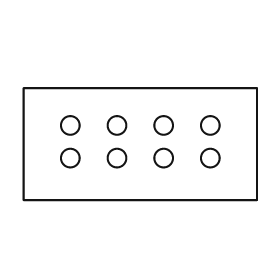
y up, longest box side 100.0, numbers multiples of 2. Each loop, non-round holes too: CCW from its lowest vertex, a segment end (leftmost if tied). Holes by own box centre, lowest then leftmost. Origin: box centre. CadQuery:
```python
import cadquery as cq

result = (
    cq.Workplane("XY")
    .moveTo(-50.0, -24.0)
    .lineTo(50.0, -24.0)
    .lineTo(50.0, 24.0)
    .lineTo(-50.0, 24.0)
    .close()
    .moveTo(-30.0, -6.0)
    .circle(4.0)
    .moveTo(-10.0, -6.0)
    .circle(4.0)
    .moveTo(10.0, -6.0)
    .circle(4.0)
    .moveTo(30.0, -6.0)
    .circle(4.0)
    .moveTo(-30.0, 8.0)
    .circle(4.0)
    .moveTo(-10.0, 8.0)
    .circle(4.0)
    .moveTo(10.0, 8.0)
    .circle(4.0)
    .moveTo(30.0, 8.0)
    .circle(4.0)
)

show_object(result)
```